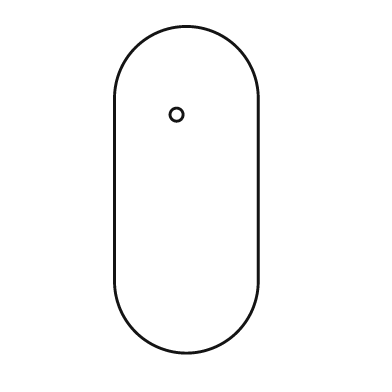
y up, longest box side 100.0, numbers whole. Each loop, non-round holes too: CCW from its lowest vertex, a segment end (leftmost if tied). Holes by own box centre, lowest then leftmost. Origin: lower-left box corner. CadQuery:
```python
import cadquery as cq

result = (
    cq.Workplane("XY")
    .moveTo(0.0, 22.0)
    .threePointArc((22.0, 0.0), (44.0, 22.0))
    .lineTo(44.0, 78.0)
    .threePointArc((22.0, 100.0), (0.0, 78.0))
    .close()
    .moveTo(19.0, 73.0)
    .circle(2.0)
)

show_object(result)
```